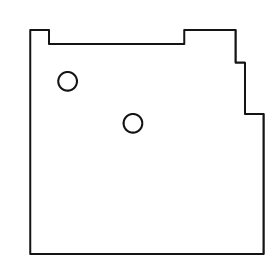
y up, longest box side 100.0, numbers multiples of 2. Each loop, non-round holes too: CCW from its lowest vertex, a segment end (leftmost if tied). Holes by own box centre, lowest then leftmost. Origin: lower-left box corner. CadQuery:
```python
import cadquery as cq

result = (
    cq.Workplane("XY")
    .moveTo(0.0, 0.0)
    .lineTo(100.0, 0.0)
    .lineTo(100.0, 60.0)
    .lineTo(92.0, 60.0)
    .lineTo(92.0, 82.0)
    .lineTo(88.0, 82.0)
    .lineTo(88.0, 96.0)
    .lineTo(66.0, 96.0)
    .lineTo(66.0, 90.0)
    .lineTo(8.0, 90.0)
    .lineTo(8.0, 96.0)
    .lineTo(0.0, 96.0)
    .close()
    .moveTo(44.0, 56.0)
    .circle(4.0)
    .moveTo(16.0, 74.0)
    .circle(4.0)
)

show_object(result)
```